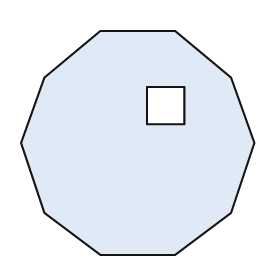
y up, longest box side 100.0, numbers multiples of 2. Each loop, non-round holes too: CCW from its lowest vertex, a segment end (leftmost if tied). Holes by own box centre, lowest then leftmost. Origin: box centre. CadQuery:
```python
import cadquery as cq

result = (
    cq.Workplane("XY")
    .moveTo(-16.0, -48.0)
    .lineTo(16.0, -48.0)
    .lineTo(40.0, -30.0)
    .lineTo(50.0, 0.0)
    .lineTo(40.0, 28.0)
    .lineTo(16.0, 48.0)
    .lineTo(-16.0, 48.0)
    .lineTo(-40.0, 28.0)
    .lineTo(-50.0, 0.0)
    .lineTo(-40.0, -30.0)
    .close()
    .moveTo(4.0, 8.0)
    .lineTo(20.0, 8.0)
    .lineTo(20.0, 24.0)
    .lineTo(4.0, 24.0)
    .close()
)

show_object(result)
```